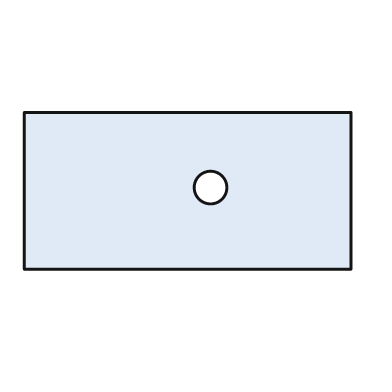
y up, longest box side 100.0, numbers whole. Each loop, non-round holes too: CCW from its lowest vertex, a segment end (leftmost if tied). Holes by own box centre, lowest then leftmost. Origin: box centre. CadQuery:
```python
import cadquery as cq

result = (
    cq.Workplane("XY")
    .moveTo(-50.0, -24.0)
    .lineTo(50.0, -24.0)
    .lineTo(50.0, 24.0)
    .lineTo(-50.0, 24.0)
    .close()
    .moveTo(7.0, 1.0)
    .circle(5.0)
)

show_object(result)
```